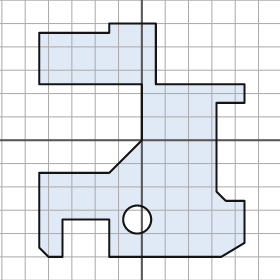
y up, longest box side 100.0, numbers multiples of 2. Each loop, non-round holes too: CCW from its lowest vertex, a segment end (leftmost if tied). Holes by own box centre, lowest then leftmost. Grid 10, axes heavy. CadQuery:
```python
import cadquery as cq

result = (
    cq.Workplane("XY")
    .moveTo(-40.0, -50.0)
    .lineTo(-34.0, -50.0)
    .lineTo(-34.0, -34.0)
    .lineTo(-14.0, -34.0)
    .lineTo(-14.0, -50.0)
    .lineTo(34.0, -50.0)
    .lineTo(44.0, -44.0)
    .lineTo(44.0, -26.0)
    .lineTo(36.0, -26.0)
    .lineTo(32.0, -22.0)
    .lineTo(32.0, 16.0)
    .lineTo(44.0, 16.0)
    .lineTo(44.0, 24.0)
    .lineTo(6.0, 24.0)
    .lineTo(6.0, 50.0)
    .lineTo(-14.0, 50.0)
    .lineTo(-14.0, 46.0)
    .lineTo(-44.0, 46.0)
    .lineTo(-44.0, 24.0)
    .lineTo(0.0, 24.0)
    .lineTo(0.0, 0.0)
    .lineTo(-14.0, -14.0)
    .lineTo(-44.0, -14.0)
    .lineTo(-44.0, -46.0)
    .close()
    .moveTo(-2.0, -34.0)
    .circle(6.0)
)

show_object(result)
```